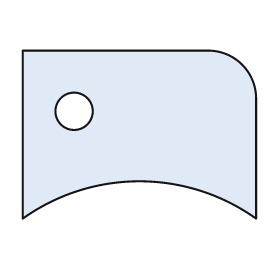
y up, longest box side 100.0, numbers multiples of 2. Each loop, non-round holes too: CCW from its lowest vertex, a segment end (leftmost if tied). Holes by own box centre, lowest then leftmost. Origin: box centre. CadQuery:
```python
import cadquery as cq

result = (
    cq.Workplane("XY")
    .moveTo(-50.0, -36.0)
    .threePointArc((0.0, -20.0), (50.0, -36.0))
    .lineTo(50.0, 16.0)
    .threePointArc((44.0, 30.0), (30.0, 36.0))
    .lineTo(-50.0, 36.0)
    .close()
    .moveTo(-28.0, 10.0)
    .circle(8.0)
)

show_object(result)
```